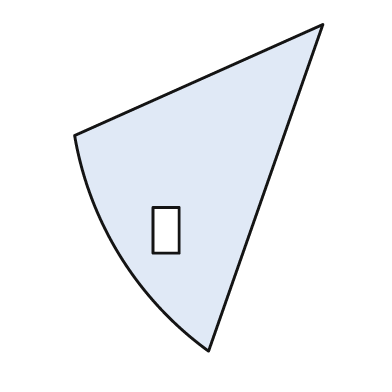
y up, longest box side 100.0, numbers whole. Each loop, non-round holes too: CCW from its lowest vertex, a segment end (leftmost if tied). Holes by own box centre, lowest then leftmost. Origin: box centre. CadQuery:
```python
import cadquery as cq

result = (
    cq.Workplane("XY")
    .moveTo(3.0, -50.0)
    .lineTo(38.0, 50.0)
    .lineTo(-38.0, 16.0)
    .threePointArc((-24.0, -21.0), (3.0, -50.0))
    .close()
    .moveTo(-14.0, -20.0)
    .lineTo(-6.0, -20.0)
    .lineTo(-6.0, -6.0)
    .lineTo(-14.0, -6.0)
    .close()
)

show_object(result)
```